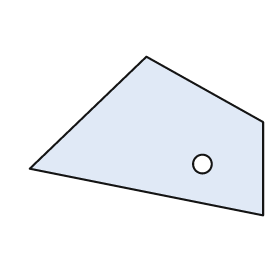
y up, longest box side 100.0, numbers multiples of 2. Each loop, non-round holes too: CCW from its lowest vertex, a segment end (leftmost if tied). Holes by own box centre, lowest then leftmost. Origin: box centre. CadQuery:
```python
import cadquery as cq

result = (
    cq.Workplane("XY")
    .moveTo(50.0, -34.0)
    .lineTo(50.0, 6.0)
    .lineTo(0.0, 34.0)
    .lineTo(-50.0, -14.0)
    .close()
    .moveTo(24.0, -12.0)
    .circle(4.0)
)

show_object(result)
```